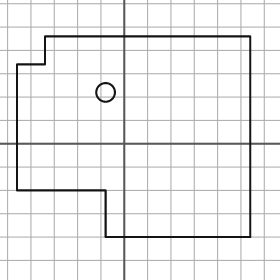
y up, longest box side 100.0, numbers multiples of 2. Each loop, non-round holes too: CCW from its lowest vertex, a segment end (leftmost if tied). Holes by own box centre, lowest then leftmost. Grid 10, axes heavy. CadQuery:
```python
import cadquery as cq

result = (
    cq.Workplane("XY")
    .moveTo(-8.0, -40.0)
    .lineTo(54.0, -40.0)
    .lineTo(54.0, 46.0)
    .lineTo(-34.0, 46.0)
    .lineTo(-34.0, 34.0)
    .lineTo(-46.0, 34.0)
    .lineTo(-46.0, -20.0)
    .lineTo(-8.0, -20.0)
    .close()
    .moveTo(-8.0, 22.0)
    .circle(4.0)
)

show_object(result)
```